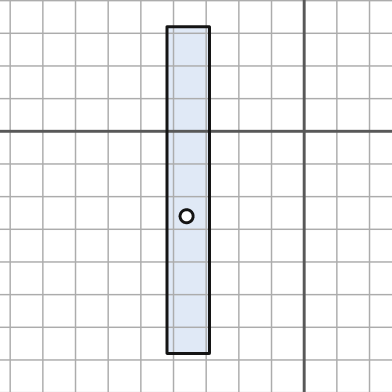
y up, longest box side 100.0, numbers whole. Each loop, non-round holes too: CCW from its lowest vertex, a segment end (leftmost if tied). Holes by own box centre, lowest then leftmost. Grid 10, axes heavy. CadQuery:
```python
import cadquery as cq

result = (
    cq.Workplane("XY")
    .moveTo(-42.0, -68.0)
    .lineTo(-29.0, -68.0)
    .lineTo(-29.0, 32.0)
    .lineTo(-42.0, 32.0)
    .close()
    .moveTo(-36.0, -26.0)
    .circle(2.0)
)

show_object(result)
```